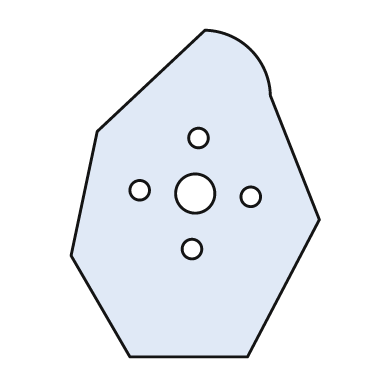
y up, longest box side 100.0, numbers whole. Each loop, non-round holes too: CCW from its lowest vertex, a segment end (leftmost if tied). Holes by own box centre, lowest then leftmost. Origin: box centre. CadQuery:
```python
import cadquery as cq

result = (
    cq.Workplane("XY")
    .moveTo(-20.0, -50.0)
    .lineTo(16.0, -50.0)
    .lineTo(38.0, -8.0)
    .lineTo(23.0, 30.0)
    .threePointArc((17.0, 44.0), (3.0, 50.0))
    .lineTo(-30.0, 19.0)
    .lineTo(-38.0, -19.0)
    .close()
    .moveTo(-1.0, -17.0)
    .circle(3.0)
    .moveTo(17.0, -1.0)
    .circle(3.0)
    .moveTo(0.0, 0.0)
    .circle(6.0)
    .moveTo(-17.0, 1.0)
    .circle(3.0)
    .moveTo(1.0, 17.0)
    .circle(3.0)
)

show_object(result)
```